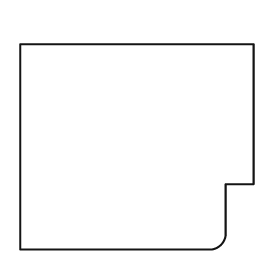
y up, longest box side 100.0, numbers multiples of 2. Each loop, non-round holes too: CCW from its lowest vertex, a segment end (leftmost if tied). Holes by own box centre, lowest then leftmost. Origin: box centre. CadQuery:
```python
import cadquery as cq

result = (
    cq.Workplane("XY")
    .moveTo(-50.0, -44.0)
    .lineTo(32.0, -44.0)
    .threePointArc((36.0, -42.0), (38.0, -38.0))
    .lineTo(38.0, -16.0)
    .lineTo(50.0, -16.0)
    .lineTo(50.0, 44.0)
    .lineTo(-50.0, 44.0)
    .close()
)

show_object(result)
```